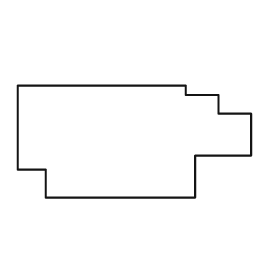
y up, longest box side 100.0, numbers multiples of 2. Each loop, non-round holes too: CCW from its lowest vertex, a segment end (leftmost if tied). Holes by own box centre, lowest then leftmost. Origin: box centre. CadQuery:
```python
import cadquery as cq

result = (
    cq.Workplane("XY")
    .moveTo(-38.0, -24.0)
    .lineTo(26.0, -24.0)
    .lineTo(26.0, -6.0)
    .lineTo(50.0, -6.0)
    .lineTo(50.0, 12.0)
    .lineTo(36.0, 12.0)
    .lineTo(36.0, 20.0)
    .lineTo(22.0, 20.0)
    .lineTo(22.0, 24.0)
    .lineTo(-50.0, 24.0)
    .lineTo(-50.0, -12.0)
    .lineTo(-38.0, -12.0)
    .close()
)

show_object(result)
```